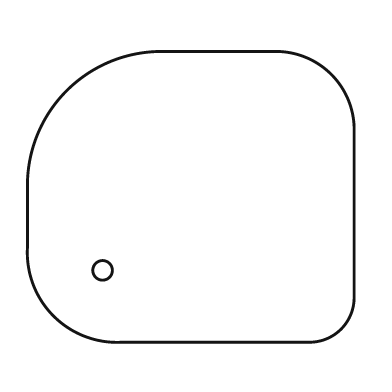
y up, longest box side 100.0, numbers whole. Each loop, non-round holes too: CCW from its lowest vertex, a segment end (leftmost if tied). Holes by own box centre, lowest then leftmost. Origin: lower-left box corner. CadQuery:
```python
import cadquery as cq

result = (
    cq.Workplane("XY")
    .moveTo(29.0, 0.0)
    .lineTo(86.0, 0.0)
    .threePointArc((96.0, 4.0), (100.0, 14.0))
    .lineTo(100.0, 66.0)
    .threePointArc((93.0, 82.0), (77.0, 89.0))
    .lineTo(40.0, 89.0)
    .threePointArc((12.0, 77.0), (0.0, 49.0))
    .lineTo(0.0, 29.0)
    .threePointArc((8.0, 8.0), (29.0, 0.0))
    .close()
    .moveTo(23.0, 22.0)
    .circle(3.0)
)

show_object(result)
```